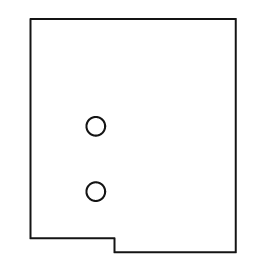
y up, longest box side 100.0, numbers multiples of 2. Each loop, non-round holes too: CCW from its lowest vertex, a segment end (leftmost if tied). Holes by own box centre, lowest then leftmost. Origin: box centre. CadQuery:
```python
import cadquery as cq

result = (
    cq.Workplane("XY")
    .moveTo(-8.0, -50.0)
    .lineTo(44.0, -50.0)
    .lineTo(44.0, 50.0)
    .lineTo(-44.0, 50.0)
    .lineTo(-44.0, -44.0)
    .lineTo(-8.0, -44.0)
    .close()
    .moveTo(-16.0, -24.0)
    .circle(4.0)
    .moveTo(-16.0, 4.0)
    .circle(4.0)
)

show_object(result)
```